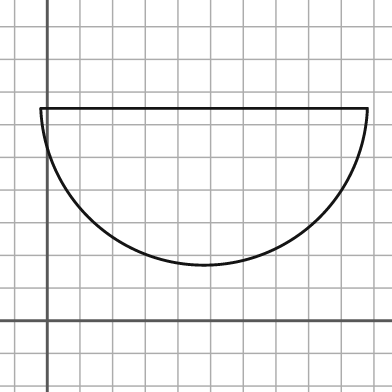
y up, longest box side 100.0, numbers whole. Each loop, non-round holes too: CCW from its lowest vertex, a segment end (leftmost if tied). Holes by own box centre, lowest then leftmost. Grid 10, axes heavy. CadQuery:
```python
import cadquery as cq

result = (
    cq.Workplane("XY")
    .moveTo(-2.0, 65.0)
    .threePointArc((48.0, 17.0), (98.0, 65.0))
    .close()
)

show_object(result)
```